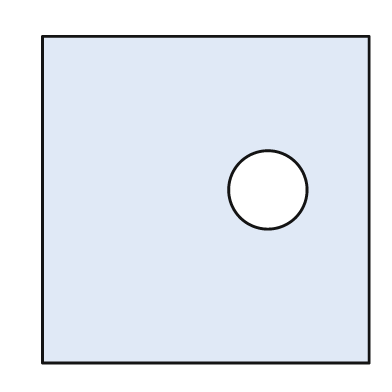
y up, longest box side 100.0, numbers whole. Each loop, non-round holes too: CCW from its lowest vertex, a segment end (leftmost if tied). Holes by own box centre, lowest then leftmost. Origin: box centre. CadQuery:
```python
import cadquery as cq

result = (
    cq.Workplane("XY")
    .moveTo(-50.0, -50.0)
    .lineTo(50.0, -50.0)
    .lineTo(50.0, 50.0)
    .lineTo(-50.0, 50.0)
    .close()
    .moveTo(19.0, 3.0)
    .circle(12.0)
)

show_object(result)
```